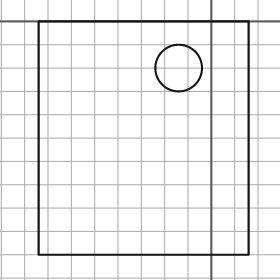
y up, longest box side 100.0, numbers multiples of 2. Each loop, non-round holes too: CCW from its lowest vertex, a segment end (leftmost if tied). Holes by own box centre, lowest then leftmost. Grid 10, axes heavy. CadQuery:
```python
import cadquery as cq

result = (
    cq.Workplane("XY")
    .moveTo(-74.0, -100.0)
    .lineTo(16.0, -100.0)
    .lineTo(16.0, 0.0)
    .lineTo(-74.0, 0.0)
    .close()
    .moveTo(-14.0, -20.0)
    .circle(10.0)
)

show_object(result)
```